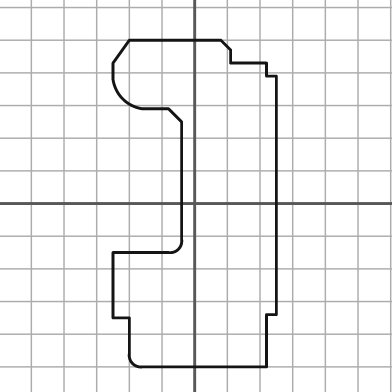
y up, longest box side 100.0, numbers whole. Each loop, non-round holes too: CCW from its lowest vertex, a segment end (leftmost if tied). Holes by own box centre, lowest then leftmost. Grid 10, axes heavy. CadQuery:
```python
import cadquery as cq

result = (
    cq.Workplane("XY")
    .moveTo(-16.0, -50.0)
    .lineTo(22.0, -50.0)
    .lineTo(22.0, -34.0)
    .lineTo(25.0, -34.0)
    .lineTo(25.0, 39.0)
    .lineTo(22.0, 39.0)
    .lineTo(22.0, 43.0)
    .lineTo(11.0, 43.0)
    .lineTo(11.0, 47.0)
    .lineTo(8.0, 50.0)
    .lineTo(-20.0, 50.0)
    .lineTo(-25.0, 43.0)
    .lineTo(-25.0, 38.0)
    .threePointArc((-22.0, 32.0), (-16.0, 29.0))
    .lineTo(-8.0, 29.0)
    .lineTo(-4.0, 25.0)
    .lineTo(-4.0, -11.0)
    .threePointArc((-5.0, -14.0), (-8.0, -15.0))
    .lineTo(-25.0, -15.0)
    .lineTo(-25.0, -35.0)
    .lineTo(-20.0, -35.0)
    .lineTo(-20.0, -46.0)
    .threePointArc((-19.0, -49.0), (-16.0, -50.0))
    .close()
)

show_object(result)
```